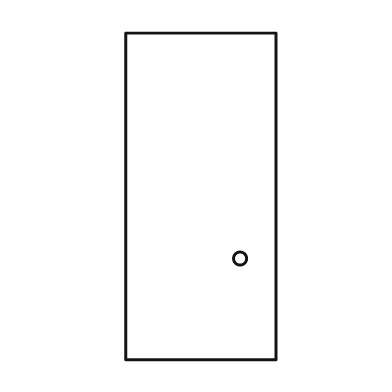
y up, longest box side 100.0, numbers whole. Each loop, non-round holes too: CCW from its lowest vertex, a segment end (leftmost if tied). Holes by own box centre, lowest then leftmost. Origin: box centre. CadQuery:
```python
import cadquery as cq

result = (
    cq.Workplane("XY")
    .moveTo(-23.0, -50.0)
    .lineTo(23.0, -50.0)
    .lineTo(23.0, 50.0)
    .lineTo(-23.0, 50.0)
    .close()
    .moveTo(12.0, -19.0)
    .circle(2.0)
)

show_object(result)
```